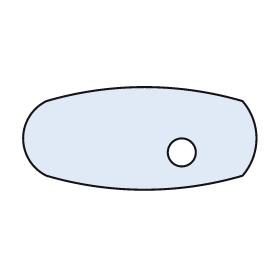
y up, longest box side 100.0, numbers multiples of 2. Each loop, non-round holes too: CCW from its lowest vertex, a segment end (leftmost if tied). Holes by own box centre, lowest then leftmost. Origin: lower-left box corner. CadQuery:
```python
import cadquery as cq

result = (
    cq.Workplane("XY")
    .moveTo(10.0, 6.0)
    .threePointArc((52.0, 0.0), (94.0, 6.0))
    .threePointArc((100.0, 22.0), (94.0, 38.0))
    .threePointArc((52.0, 44.0), (10.0, 38.0))
    .threePointArc((0.0, 22.0), (10.0, 6.0))
    .close()
    .moveTo(68.0, 16.0)
    .circle(6.0)
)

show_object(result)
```